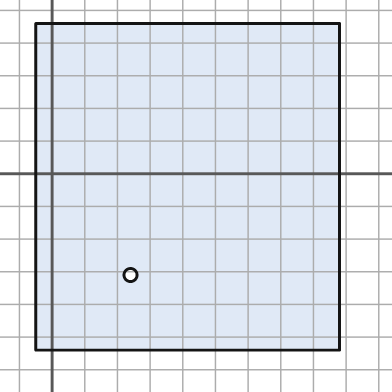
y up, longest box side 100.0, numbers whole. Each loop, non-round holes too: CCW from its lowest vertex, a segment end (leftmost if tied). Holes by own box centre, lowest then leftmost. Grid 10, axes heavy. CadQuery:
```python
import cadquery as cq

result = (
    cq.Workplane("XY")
    .moveTo(-5.0, -54.0)
    .lineTo(88.0, -54.0)
    .lineTo(88.0, 46.0)
    .lineTo(-5.0, 46.0)
    .close()
    .moveTo(24.0, -31.0)
    .circle(2.0)
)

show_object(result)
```